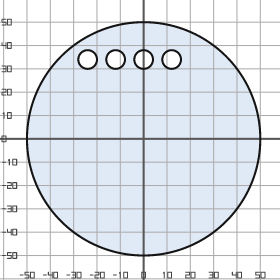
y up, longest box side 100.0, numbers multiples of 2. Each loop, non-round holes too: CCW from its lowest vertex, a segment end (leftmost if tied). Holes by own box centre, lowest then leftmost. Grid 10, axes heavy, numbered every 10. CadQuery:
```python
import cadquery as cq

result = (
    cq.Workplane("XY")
    .moveTo(0.0, 0.0)
    .circle(50.0)
    .moveTo(-24.0, 34.0)
    .circle(4.0)
    .moveTo(-12.0, 34.0)
    .circle(4.0)
    .moveTo(0.0, 34.0)
    .circle(4.0)
    .moveTo(12.0, 34.0)
    .circle(4.0)
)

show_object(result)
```